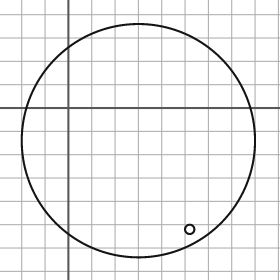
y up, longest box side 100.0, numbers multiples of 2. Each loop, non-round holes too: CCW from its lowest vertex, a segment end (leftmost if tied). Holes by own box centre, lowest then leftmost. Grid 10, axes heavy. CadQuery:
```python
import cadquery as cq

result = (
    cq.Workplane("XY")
    .moveTo(30.0, -14.0)
    .circle(50.0)
    .moveTo(52.0, -52.0)
    .circle(2.0)
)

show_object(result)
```